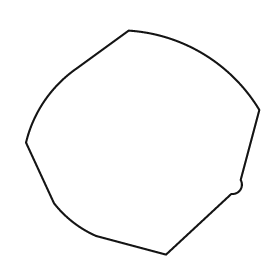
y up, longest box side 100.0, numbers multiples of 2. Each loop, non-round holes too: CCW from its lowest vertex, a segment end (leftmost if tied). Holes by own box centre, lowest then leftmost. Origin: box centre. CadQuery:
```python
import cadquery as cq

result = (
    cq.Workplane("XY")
    .moveTo(10.0, -48.0)
    .lineTo(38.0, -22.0)
    .threePointArc((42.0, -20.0), (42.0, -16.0))
    .lineTo(50.0, 14.0)
    .threePointArc((26.0, 38.0), (-6.0, 48.0))
    .lineTo(-28.0, 32.0)
    .threePointArc((-42.0, 18.0), (-50.0, 0.0))
    .lineTo(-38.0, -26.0)
    .threePointArc((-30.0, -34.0), (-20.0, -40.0))
    .close()
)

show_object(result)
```